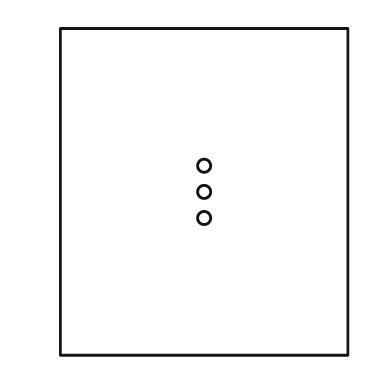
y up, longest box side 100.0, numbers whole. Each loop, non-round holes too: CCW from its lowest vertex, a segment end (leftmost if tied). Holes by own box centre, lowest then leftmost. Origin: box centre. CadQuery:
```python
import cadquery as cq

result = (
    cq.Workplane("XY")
    .moveTo(-44.0, -50.0)
    .lineTo(44.0, -50.0)
    .lineTo(44.0, 50.0)
    .lineTo(-44.0, 50.0)
    .close()
    .moveTo(0.0, -8.0)
    .circle(2.0)
    .moveTo(0.0, 0.0)
    .circle(2.0)
    .moveTo(0.0, 8.0)
    .circle(2.0)
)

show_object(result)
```